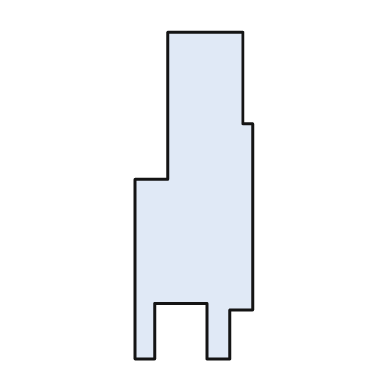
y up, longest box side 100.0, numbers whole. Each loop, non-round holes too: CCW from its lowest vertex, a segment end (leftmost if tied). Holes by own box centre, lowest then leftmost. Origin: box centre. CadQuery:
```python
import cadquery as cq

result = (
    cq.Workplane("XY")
    .moveTo(-18.0, -50.0)
    .lineTo(-12.0, -50.0)
    .lineTo(-12.0, -33.0)
    .lineTo(4.0, -33.0)
    .lineTo(4.0, -50.0)
    .lineTo(11.0, -50.0)
    .lineTo(11.0, -35.0)
    .lineTo(18.0, -35.0)
    .lineTo(18.0, 22.0)
    .lineTo(15.0, 22.0)
    .lineTo(15.0, 50.0)
    .lineTo(-8.0, 50.0)
    .lineTo(-8.0, 5.0)
    .lineTo(-18.0, 5.0)
    .close()
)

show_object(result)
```